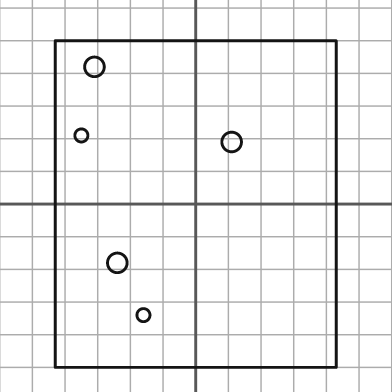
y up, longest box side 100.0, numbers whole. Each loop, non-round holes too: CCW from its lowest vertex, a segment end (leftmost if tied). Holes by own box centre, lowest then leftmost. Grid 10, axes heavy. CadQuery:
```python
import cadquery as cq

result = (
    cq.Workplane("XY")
    .moveTo(-43.0, -50.0)
    .lineTo(43.0, -50.0)
    .lineTo(43.0, 50.0)
    .lineTo(-43.0, 50.0)
    .close()
    .moveTo(-16.0, -34.0)
    .circle(2.0)
    .moveTo(-24.0, -18.0)
    .circle(3.0)
    .moveTo(11.0, 19.0)
    .circle(3.0)
    .moveTo(-35.0, 21.0)
    .circle(2.0)
    .moveTo(-31.0, 42.0)
    .circle(3.0)
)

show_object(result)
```